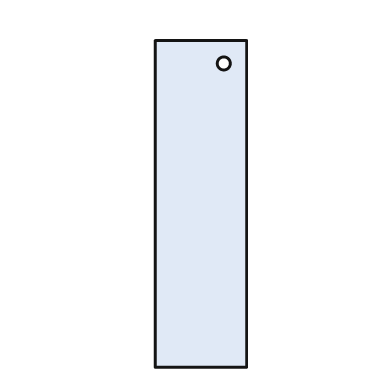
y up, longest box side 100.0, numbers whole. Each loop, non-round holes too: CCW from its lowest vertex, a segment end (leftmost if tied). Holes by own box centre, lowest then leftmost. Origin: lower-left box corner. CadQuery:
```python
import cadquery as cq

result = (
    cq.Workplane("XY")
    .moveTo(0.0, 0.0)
    .lineTo(28.0, 0.0)
    .lineTo(28.0, 100.0)
    .lineTo(0.0, 100.0)
    .close()
    .moveTo(21.0, 93.0)
    .circle(2.0)
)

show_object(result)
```